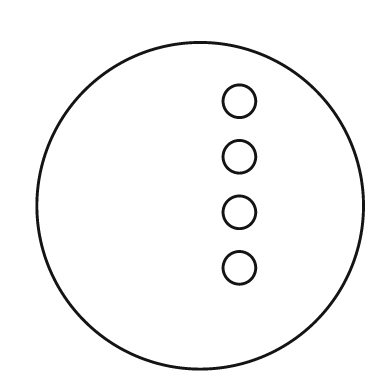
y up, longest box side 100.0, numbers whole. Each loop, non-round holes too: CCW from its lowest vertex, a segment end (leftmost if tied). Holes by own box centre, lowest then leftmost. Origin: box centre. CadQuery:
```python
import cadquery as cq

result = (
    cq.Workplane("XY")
    .moveTo(0.0, 0.0)
    .circle(50.0)
    .moveTo(12.0, -19.0)
    .circle(5.0)
    .moveTo(12.0, -2.0)
    .circle(5.0)
    .moveTo(12.0, 15.0)
    .circle(5.0)
    .moveTo(12.0, 32.0)
    .circle(5.0)
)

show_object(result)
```